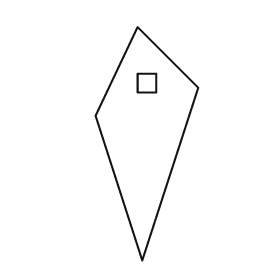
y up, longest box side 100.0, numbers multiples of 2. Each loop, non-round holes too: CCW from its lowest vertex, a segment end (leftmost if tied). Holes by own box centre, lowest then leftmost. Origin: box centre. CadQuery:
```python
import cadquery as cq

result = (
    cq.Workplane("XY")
    .moveTo(-2.0, -50.0)
    .lineTo(22.0, 24.0)
    .lineTo(-4.0, 50.0)
    .lineTo(-22.0, 12.0)
    .close()
    .moveTo(-4.0, 22.0)
    .lineTo(4.0, 22.0)
    .lineTo(4.0, 30.0)
    .lineTo(-4.0, 30.0)
    .close()
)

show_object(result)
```